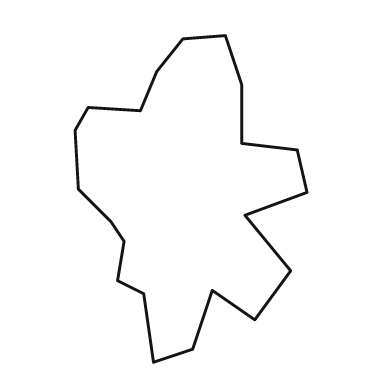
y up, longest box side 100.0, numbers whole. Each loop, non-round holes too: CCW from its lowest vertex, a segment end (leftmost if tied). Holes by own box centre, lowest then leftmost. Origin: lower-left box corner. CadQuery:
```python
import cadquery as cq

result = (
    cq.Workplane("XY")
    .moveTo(24.0, 0.0)
    .lineTo(36.0, 4.0)
    .lineTo(42.0, 22.0)
    .lineTo(55.0, 13.0)
    .lineTo(66.0, 28.0)
    .lineTo(52.0, 45.0)
    .lineTo(71.0, 52.0)
    .lineTo(68.0, 65.0)
    .lineTo(51.0, 67.0)
    .lineTo(51.0, 85.0)
    .lineTo(46.0, 100.0)
    .lineTo(33.0, 99.0)
    .lineTo(25.0, 89.0)
    .lineTo(20.0, 77.0)
    .lineTo(4.0, 78.0)
    .lineTo(0.0, 71.0)
    .lineTo(1.0, 53.0)
    .lineTo(11.0, 43.0)
    .lineTo(15.0, 37.0)
    .lineTo(13.0, 25.0)
    .lineTo(21.0, 21.0)
    .close()
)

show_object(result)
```